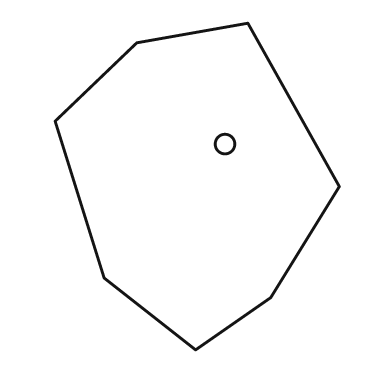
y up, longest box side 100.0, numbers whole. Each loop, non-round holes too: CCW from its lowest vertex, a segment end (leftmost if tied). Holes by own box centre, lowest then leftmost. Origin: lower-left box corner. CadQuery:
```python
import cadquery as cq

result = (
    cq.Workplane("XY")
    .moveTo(43.0, 0.0)
    .lineTo(66.0, 16.0)
    .lineTo(87.0, 50.0)
    .lineTo(59.0, 100.0)
    .lineTo(25.0, 94.0)
    .lineTo(0.0, 70.0)
    .lineTo(15.0, 22.0)
    .close()
    .moveTo(52.0, 63.0)
    .circle(3.0)
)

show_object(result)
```